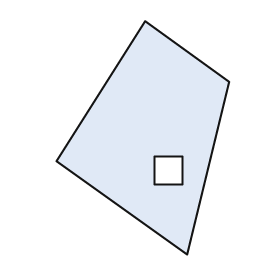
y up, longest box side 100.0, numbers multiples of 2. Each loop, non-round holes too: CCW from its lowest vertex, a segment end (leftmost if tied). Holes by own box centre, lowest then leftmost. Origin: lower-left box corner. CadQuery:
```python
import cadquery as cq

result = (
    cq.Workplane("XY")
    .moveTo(56.0, 0.0)
    .lineTo(74.0, 74.0)
    .lineTo(38.0, 100.0)
    .lineTo(0.0, 40.0)
    .close()
    .moveTo(42.0, 30.0)
    .lineTo(54.0, 30.0)
    .lineTo(54.0, 42.0)
    .lineTo(42.0, 42.0)
    .close()
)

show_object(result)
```